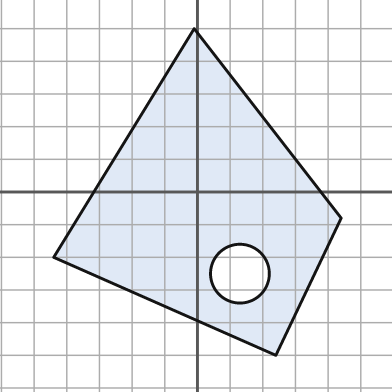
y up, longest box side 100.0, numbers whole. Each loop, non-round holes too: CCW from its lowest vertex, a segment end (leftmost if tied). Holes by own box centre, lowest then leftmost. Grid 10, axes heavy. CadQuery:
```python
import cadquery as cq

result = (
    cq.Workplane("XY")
    .moveTo(24.0, -50.0)
    .lineTo(44.0, -8.0)
    .lineTo(-1.0, 50.0)
    .lineTo(-44.0, -20.0)
    .close()
    .moveTo(13.0, -25.0)
    .circle(9.0)
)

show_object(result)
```